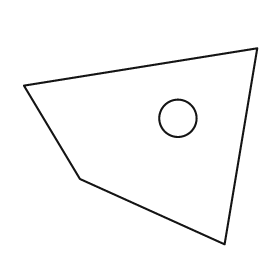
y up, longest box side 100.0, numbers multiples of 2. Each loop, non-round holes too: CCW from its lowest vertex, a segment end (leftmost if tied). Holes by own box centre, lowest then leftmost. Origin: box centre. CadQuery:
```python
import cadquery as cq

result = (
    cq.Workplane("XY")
    .moveTo(36.0, -42.0)
    .lineTo(50.0, 42.0)
    .lineTo(-50.0, 26.0)
    .lineTo(-26.0, -14.0)
    .close()
    .moveTo(16.0, 12.0)
    .circle(8.0)
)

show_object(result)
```